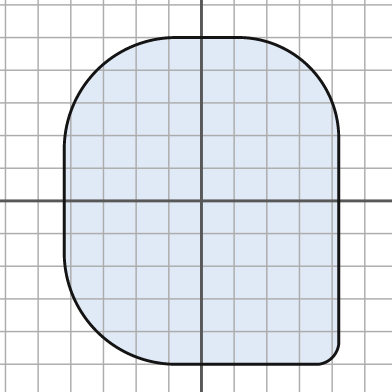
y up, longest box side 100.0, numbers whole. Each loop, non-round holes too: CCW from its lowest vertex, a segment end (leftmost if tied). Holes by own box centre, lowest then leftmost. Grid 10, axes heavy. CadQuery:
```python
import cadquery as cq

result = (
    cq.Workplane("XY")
    .moveTo(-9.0, -50.0)
    .lineTo(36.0, -50.0)
    .threePointArc((40.0, -48.0), (42.0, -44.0))
    .lineTo(42.0, 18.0)
    .threePointArc((33.0, 41.0), (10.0, 50.0))
    .lineTo(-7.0, 50.0)
    .threePointArc((-32.0, 40.0), (-42.0, 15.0))
    .lineTo(-42.0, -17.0)
    .threePointArc((-32.0, -40.0), (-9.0, -50.0))
    .close()
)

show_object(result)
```